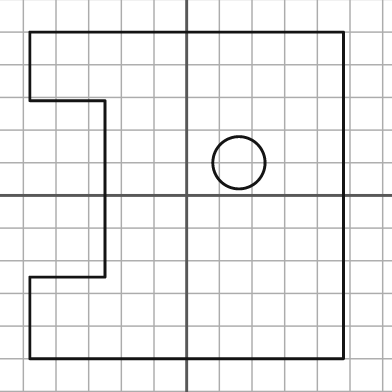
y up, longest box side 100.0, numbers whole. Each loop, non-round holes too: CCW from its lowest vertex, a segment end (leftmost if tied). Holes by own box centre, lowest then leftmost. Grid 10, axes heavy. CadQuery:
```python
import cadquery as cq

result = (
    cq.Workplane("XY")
    .moveTo(-48.0, -50.0)
    .lineTo(48.0, -50.0)
    .lineTo(48.0, 50.0)
    .lineTo(-48.0, 50.0)
    .lineTo(-48.0, 29.0)
    .lineTo(-25.0, 29.0)
    .lineTo(-25.0, -25.0)
    .lineTo(-48.0, -25.0)
    .close()
    .moveTo(16.0, 10.0)
    .circle(8.0)
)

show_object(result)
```